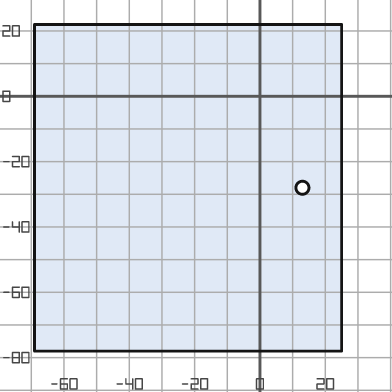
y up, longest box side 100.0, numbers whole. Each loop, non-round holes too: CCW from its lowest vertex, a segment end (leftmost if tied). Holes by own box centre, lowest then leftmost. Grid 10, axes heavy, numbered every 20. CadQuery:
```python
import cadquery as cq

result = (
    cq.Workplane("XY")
    .moveTo(-69.0, -78.0)
    .lineTo(25.0, -78.0)
    .lineTo(25.0, 22.0)
    .lineTo(-69.0, 22.0)
    .close()
    .moveTo(13.0, -28.0)
    .circle(2.0)
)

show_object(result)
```